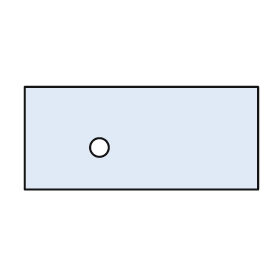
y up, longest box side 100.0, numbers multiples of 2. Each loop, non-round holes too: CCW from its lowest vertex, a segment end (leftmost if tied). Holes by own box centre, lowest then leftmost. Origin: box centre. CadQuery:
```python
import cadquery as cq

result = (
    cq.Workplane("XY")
    .moveTo(-50.0, -22.0)
    .lineTo(50.0, -22.0)
    .lineTo(50.0, 22.0)
    .lineTo(-50.0, 22.0)
    .close()
    .moveTo(-18.0, -4.0)
    .circle(4.0)
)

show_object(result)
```